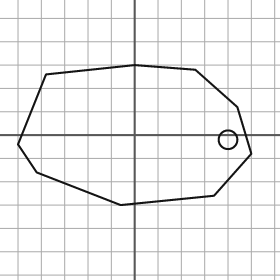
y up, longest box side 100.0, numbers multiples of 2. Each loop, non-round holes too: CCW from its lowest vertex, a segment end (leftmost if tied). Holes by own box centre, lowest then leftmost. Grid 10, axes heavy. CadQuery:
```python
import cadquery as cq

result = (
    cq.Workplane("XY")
    .moveTo(-6.0, -30.0)
    .lineTo(34.0, -26.0)
    .lineTo(50.0, -8.0)
    .lineTo(44.0, 12.0)
    .lineTo(26.0, 28.0)
    .lineTo(0.0, 30.0)
    .lineTo(-38.0, 26.0)
    .lineTo(-50.0, -4.0)
    .lineTo(-42.0, -16.0)
    .close()
    .moveTo(40.0, -2.0)
    .circle(4.0)
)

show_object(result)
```